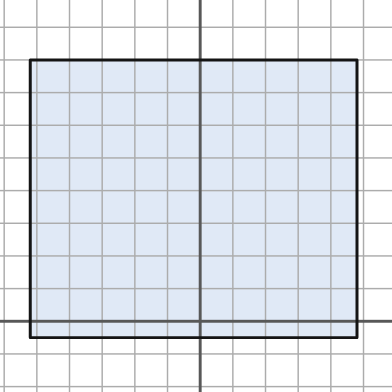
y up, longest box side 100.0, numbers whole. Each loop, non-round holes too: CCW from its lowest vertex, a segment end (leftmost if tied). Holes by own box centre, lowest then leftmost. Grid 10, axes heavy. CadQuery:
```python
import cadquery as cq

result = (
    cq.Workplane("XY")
    .moveTo(-52.0, -5.0)
    .lineTo(48.0, -5.0)
    .lineTo(48.0, 80.0)
    .lineTo(-52.0, 80.0)
    .close()
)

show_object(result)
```